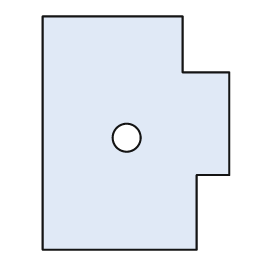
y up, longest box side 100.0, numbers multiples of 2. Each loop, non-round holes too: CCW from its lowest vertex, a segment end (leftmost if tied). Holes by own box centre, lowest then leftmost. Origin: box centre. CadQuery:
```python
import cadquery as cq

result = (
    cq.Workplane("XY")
    .moveTo(-40.0, -50.0)
    .lineTo(26.0, -50.0)
    .lineTo(26.0, -18.0)
    .lineTo(40.0, -18.0)
    .lineTo(40.0, 26.0)
    .lineTo(20.0, 26.0)
    .lineTo(20.0, 50.0)
    .lineTo(-40.0, 50.0)
    .close()
    .moveTo(-4.0, -2.0)
    .circle(6.0)
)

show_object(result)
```